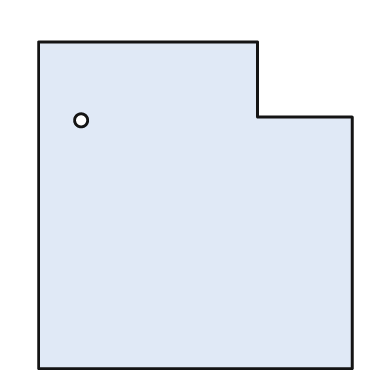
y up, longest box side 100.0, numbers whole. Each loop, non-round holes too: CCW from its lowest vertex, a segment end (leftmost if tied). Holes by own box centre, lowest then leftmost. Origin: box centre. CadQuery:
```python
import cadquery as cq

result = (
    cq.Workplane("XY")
    .moveTo(-48.0, -50.0)
    .lineTo(48.0, -50.0)
    .lineTo(48.0, 27.0)
    .lineTo(19.0, 27.0)
    .lineTo(19.0, 50.0)
    .lineTo(-48.0, 50.0)
    .close()
    .moveTo(-35.0, 26.0)
    .circle(2.0)
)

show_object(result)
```